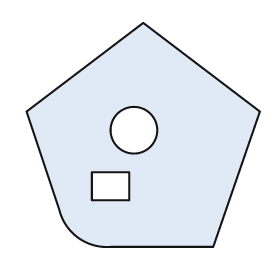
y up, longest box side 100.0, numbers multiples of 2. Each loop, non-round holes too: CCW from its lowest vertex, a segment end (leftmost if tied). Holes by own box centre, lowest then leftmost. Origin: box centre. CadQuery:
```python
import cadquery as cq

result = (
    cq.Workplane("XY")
    .moveTo(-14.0, -48.0)
    .lineTo(30.0, -48.0)
    .lineTo(50.0, 10.0)
    .lineTo(0.0, 48.0)
    .lineTo(-50.0, 10.0)
    .lineTo(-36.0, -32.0)
    .threePointArc((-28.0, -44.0), (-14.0, -48.0))
    .close()
    .moveTo(-22.0, -28.0)
    .lineTo(-6.0, -28.0)
    .lineTo(-6.0, -16.0)
    .lineTo(-22.0, -16.0)
    .close()
    .moveTo(-4.0, 2.0)
    .circle(10.0)
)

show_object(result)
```